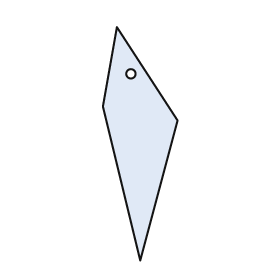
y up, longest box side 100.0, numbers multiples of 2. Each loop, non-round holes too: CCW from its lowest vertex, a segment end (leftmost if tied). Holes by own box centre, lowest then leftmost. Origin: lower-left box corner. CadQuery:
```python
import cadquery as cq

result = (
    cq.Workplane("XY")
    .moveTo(16.0, 0.0)
    .lineTo(32.0, 60.0)
    .lineTo(6.0, 100.0)
    .lineTo(0.0, 66.0)
    .close()
    .moveTo(12.0, 80.0)
    .circle(2.0)
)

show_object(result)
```